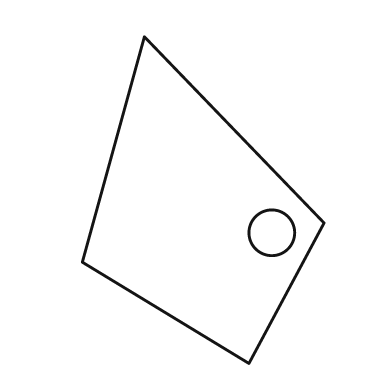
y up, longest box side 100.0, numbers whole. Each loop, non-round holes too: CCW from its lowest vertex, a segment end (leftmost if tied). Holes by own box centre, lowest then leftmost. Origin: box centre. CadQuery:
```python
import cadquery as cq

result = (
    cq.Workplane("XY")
    .moveTo(14.0, -50.0)
    .lineTo(37.0, -7.0)
    .lineTo(-18.0, 50.0)
    .lineTo(-37.0, -19.0)
    .close()
    .moveTo(21.0, -10.0)
    .circle(7.0)
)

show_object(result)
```